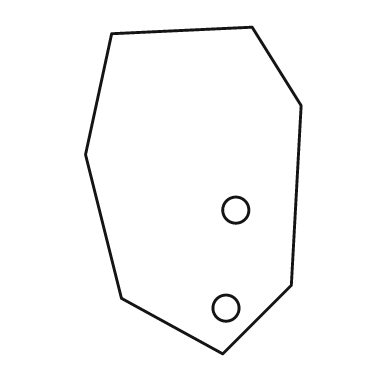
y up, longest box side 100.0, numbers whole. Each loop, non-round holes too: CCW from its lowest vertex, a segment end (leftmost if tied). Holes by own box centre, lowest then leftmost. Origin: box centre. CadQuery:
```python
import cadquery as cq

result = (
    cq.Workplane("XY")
    .moveTo(9.0, -50.0)
    .lineTo(30.0, -29.0)
    .lineTo(33.0, 26.0)
    .lineTo(18.0, 50.0)
    .lineTo(-25.0, 48.0)
    .lineTo(-33.0, 11.0)
    .lineTo(-22.0, -33.0)
    .close()
    .moveTo(10.0, -36.0)
    .circle(4.0)
    .moveTo(13.0, -6.0)
    .circle(4.0)
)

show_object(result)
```